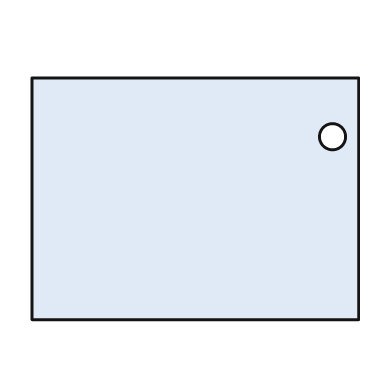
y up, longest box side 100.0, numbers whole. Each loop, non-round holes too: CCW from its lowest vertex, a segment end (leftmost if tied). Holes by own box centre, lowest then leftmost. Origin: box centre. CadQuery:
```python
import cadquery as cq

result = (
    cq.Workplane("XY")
    .moveTo(-50.0, -37.0)
    .lineTo(50.0, -37.0)
    .lineTo(50.0, 37.0)
    .lineTo(-50.0, 37.0)
    .close()
    .moveTo(42.0, 19.0)
    .circle(4.0)
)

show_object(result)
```